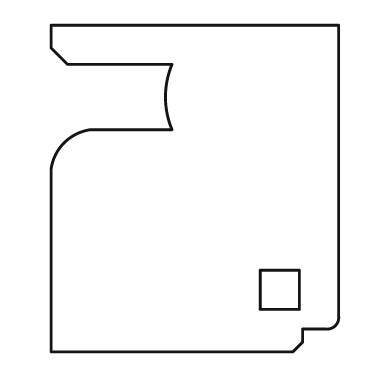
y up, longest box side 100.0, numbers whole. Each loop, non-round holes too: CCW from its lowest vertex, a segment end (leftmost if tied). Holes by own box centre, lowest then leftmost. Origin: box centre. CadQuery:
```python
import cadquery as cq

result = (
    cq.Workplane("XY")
    .moveTo(-44.0, -50.0)
    .lineTo(30.0, -50.0)
    .lineTo(33.0, -47.0)
    .lineTo(33.0, -43.0)
    .lineTo(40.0, -43.0)
    .threePointArc((43.0, -42.0), (44.0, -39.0))
    .lineTo(44.0, 50.0)
    .lineTo(-44.0, 50.0)
    .lineTo(-44.0, 43.0)
    .lineTo(-39.0, 38.0)
    .lineTo(-7.0, 38.0)
    .threePointArc((-9.0, 28.0), (-7.0, 18.0))
    .lineTo(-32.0, 18.0)
    .threePointArc((-40.0, 14.0), (-44.0, 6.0))
    .close()
    .moveTo(20.0, -37.0)
    .lineTo(32.0, -37.0)
    .lineTo(32.0, -25.0)
    .lineTo(20.0, -25.0)
    .close()
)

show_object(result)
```